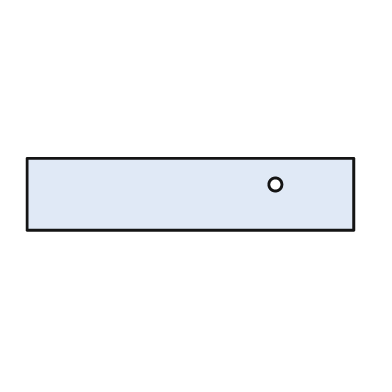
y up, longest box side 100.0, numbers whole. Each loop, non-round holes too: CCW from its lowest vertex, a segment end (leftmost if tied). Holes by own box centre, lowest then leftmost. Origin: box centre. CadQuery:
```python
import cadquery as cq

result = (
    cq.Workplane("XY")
    .moveTo(-50.0, -11.0)
    .lineTo(50.0, -11.0)
    .lineTo(50.0, 11.0)
    .lineTo(-50.0, 11.0)
    .close()
    .moveTo(26.0, 3.0)
    .circle(2.0)
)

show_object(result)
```